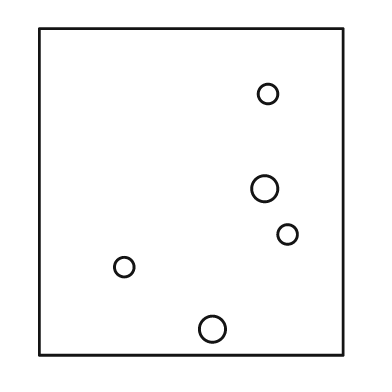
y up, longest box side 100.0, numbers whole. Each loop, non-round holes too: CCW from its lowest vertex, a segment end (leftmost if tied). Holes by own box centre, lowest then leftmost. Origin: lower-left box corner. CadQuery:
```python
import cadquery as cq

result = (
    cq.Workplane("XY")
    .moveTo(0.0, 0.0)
    .lineTo(93.0, 0.0)
    .lineTo(93.0, 100.0)
    .lineTo(0.0, 100.0)
    .close()
    .moveTo(53.0, 8.0)
    .circle(4.0)
    .moveTo(26.0, 27.0)
    .circle(3.0)
    .moveTo(76.0, 37.0)
    .circle(3.0)
    .moveTo(69.0, 51.0)
    .circle(4.0)
    .moveTo(70.0, 80.0)
    .circle(3.0)
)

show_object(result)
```